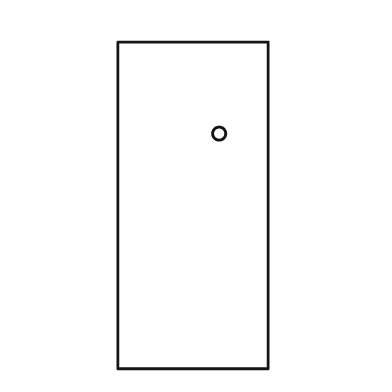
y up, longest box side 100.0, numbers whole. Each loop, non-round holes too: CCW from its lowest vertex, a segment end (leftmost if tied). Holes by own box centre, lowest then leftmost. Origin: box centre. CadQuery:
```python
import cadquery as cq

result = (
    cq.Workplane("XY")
    .moveTo(-23.0, -50.0)
    .lineTo(23.0, -50.0)
    .lineTo(23.0, 50.0)
    .lineTo(-23.0, 50.0)
    .close()
    .moveTo(8.0, 22.0)
    .circle(2.0)
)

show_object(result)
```